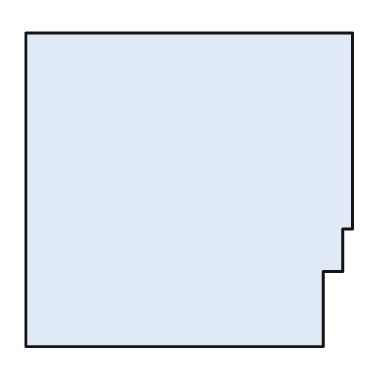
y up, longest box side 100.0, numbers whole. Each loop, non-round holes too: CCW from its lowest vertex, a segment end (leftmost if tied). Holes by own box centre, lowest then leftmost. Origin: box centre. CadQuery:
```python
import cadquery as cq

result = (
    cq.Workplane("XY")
    .moveTo(-50.0, -48.0)
    .lineTo(41.0, -48.0)
    .lineTo(41.0, -25.0)
    .lineTo(47.0, -25.0)
    .lineTo(47.0, -12.0)
    .lineTo(50.0, -12.0)
    .lineTo(50.0, 48.0)
    .lineTo(-50.0, 48.0)
    .close()
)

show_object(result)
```